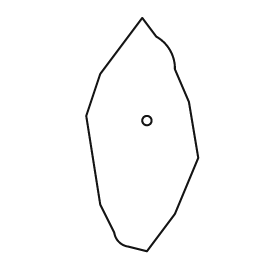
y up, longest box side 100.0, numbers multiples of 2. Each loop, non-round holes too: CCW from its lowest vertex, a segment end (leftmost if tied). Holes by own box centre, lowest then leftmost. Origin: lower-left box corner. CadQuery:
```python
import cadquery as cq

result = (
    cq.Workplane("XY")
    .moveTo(26.0, 0.0)
    .lineTo(38.0, 16.0)
    .lineTo(48.0, 40.0)
    .lineTo(44.0, 64.0)
    .lineTo(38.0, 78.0)
    .threePointArc((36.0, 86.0), (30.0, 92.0))
    .lineTo(24.0, 100.0)
    .lineTo(6.0, 76.0)
    .lineTo(0.0, 58.0)
    .lineTo(6.0, 20.0)
    .lineTo(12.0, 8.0)
    .threePointArc((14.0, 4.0), (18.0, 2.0))
    .close()
    .moveTo(26.0, 56.0)
    .circle(2.0)
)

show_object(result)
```